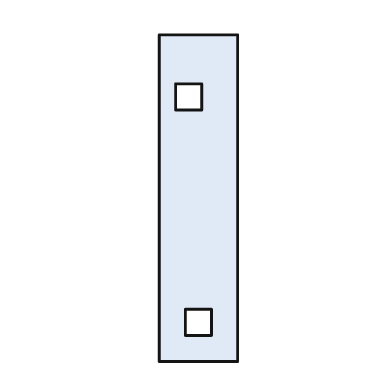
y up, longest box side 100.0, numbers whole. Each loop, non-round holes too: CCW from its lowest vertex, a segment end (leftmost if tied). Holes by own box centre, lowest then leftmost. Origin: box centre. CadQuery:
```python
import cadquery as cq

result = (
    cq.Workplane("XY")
    .moveTo(-12.0, -50.0)
    .lineTo(12.0, -50.0)
    .lineTo(12.0, 50.0)
    .lineTo(-12.0, 50.0)
    .close()
    .moveTo(-4.0, -42.0)
    .lineTo(4.0, -42.0)
    .lineTo(4.0, -34.0)
    .lineTo(-4.0, -34.0)
    .close()
    .moveTo(-7.0, 27.0)
    .lineTo(1.0, 27.0)
    .lineTo(1.0, 35.0)
    .lineTo(-7.0, 35.0)
    .close()
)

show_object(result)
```